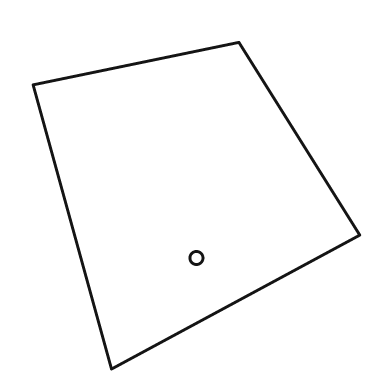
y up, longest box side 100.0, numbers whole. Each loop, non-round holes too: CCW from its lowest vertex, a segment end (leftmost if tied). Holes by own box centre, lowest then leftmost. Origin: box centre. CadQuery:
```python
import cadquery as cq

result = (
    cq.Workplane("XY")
    .moveTo(-26.0, -50.0)
    .lineTo(50.0, -9.0)
    .lineTo(13.0, 50.0)
    .lineTo(-50.0, 37.0)
    .close()
    .moveTo(0.0, -16.0)
    .circle(2.0)
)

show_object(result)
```